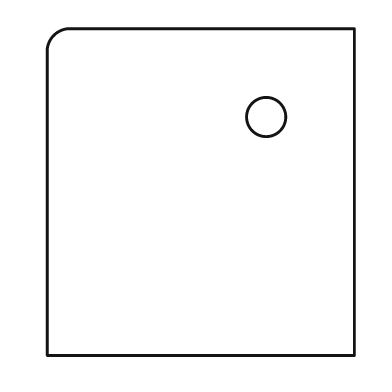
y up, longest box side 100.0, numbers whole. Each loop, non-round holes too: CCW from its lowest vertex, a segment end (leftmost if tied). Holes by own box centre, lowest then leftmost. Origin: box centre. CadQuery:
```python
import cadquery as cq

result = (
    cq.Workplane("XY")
    .moveTo(-47.0, -50.0)
    .lineTo(47.0, -50.0)
    .lineTo(47.0, 50.0)
    .lineTo(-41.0, 50.0)
    .threePointArc((-45.0, 48.0), (-47.0, 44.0))
    .close()
    .moveTo(20.0, 23.0)
    .circle(6.0)
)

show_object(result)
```